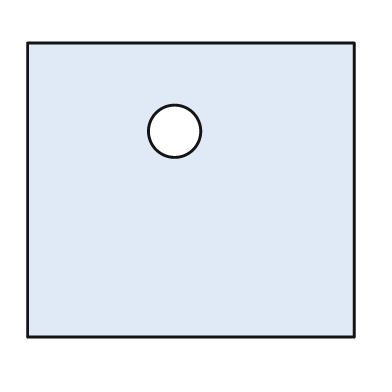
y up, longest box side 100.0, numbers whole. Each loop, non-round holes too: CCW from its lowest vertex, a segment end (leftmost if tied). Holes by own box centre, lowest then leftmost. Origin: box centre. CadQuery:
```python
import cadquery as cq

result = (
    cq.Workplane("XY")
    .moveTo(-50.0, -45.0)
    .lineTo(50.0, -45.0)
    .lineTo(50.0, 45.0)
    .lineTo(-50.0, 45.0)
    .close()
    .moveTo(-5.0, 18.0)
    .circle(8.0)
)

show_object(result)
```